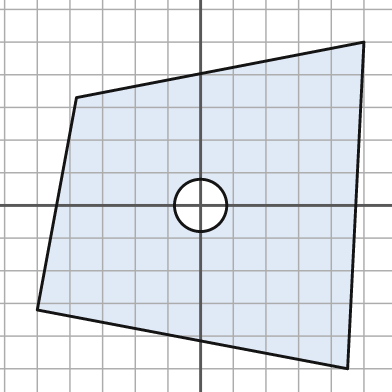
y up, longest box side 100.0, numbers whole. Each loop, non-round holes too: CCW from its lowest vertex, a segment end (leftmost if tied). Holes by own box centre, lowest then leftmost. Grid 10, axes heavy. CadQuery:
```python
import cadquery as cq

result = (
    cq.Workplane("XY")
    .moveTo(45.0, -50.0)
    .lineTo(50.0, 50.0)
    .lineTo(-38.0, 33.0)
    .lineTo(-50.0, -32.0)
    .close()
    .moveTo(0.0, 0.0)
    .circle(8.0)
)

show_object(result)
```